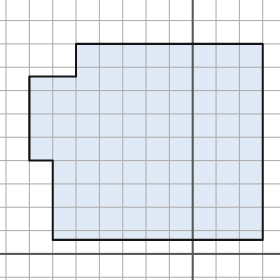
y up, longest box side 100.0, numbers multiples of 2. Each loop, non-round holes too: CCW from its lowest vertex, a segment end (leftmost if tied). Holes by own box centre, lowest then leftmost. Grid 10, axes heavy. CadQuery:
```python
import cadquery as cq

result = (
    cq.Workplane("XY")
    .moveTo(-60.0, 6.0)
    .lineTo(30.0, 6.0)
    .lineTo(30.0, 90.0)
    .lineTo(-50.0, 90.0)
    .lineTo(-50.0, 76.0)
    .lineTo(-70.0, 76.0)
    .lineTo(-70.0, 40.0)
    .lineTo(-60.0, 40.0)
    .close()
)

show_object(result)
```